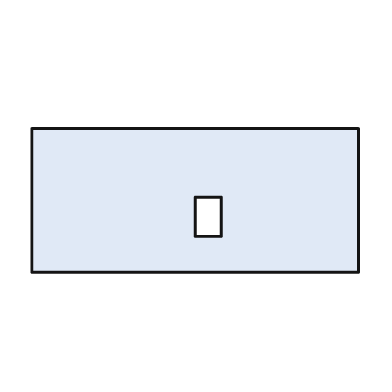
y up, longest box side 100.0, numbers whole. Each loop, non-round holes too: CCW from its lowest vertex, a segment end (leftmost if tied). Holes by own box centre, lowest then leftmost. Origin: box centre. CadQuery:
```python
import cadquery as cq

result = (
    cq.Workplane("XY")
    .moveTo(-50.0, -22.0)
    .lineTo(50.0, -22.0)
    .lineTo(50.0, 22.0)
    .lineTo(-50.0, 22.0)
    .close()
    .moveTo(0.0, -11.0)
    .lineTo(8.0, -11.0)
    .lineTo(8.0, 1.0)
    .lineTo(0.0, 1.0)
    .close()
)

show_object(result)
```